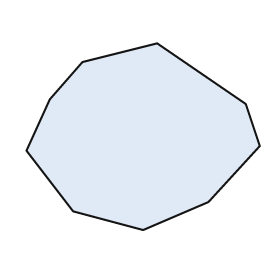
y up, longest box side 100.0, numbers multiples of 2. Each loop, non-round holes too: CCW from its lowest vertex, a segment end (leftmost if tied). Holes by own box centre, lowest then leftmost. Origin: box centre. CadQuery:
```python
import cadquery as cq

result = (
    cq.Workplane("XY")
    .moveTo(0.0, -40.0)
    .lineTo(28.0, -28.0)
    .lineTo(50.0, -4.0)
    .lineTo(44.0, 14.0)
    .lineTo(6.0, 40.0)
    .lineTo(-26.0, 32.0)
    .lineTo(-40.0, 16.0)
    .lineTo(-50.0, -6.0)
    .lineTo(-30.0, -32.0)
    .close()
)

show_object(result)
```